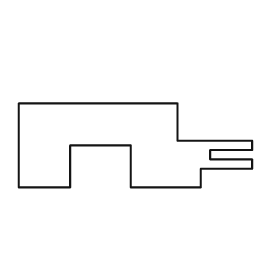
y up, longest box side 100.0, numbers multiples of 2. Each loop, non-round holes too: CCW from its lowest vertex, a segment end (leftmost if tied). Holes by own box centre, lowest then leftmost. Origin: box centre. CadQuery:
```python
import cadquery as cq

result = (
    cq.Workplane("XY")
    .moveTo(-50.0, -18.0)
    .lineTo(-28.0, -18.0)
    .lineTo(-28.0, 0.0)
    .lineTo(-2.0, 0.0)
    .lineTo(-2.0, -18.0)
    .lineTo(28.0, -18.0)
    .lineTo(28.0, -10.0)
    .lineTo(50.0, -10.0)
    .lineTo(50.0, -6.0)
    .lineTo(32.0, -6.0)
    .lineTo(32.0, -2.0)
    .lineTo(50.0, -2.0)
    .lineTo(50.0, 2.0)
    .lineTo(18.0, 2.0)
    .lineTo(18.0, 18.0)
    .lineTo(-50.0, 18.0)
    .close()
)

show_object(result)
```